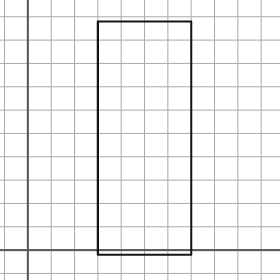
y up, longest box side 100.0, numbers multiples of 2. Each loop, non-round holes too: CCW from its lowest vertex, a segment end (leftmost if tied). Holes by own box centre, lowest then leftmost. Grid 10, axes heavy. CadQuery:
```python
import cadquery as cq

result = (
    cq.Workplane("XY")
    .moveTo(30.0, -2.0)
    .lineTo(70.0, -2.0)
    .lineTo(70.0, 98.0)
    .lineTo(30.0, 98.0)
    .close()
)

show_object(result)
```